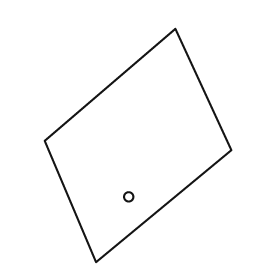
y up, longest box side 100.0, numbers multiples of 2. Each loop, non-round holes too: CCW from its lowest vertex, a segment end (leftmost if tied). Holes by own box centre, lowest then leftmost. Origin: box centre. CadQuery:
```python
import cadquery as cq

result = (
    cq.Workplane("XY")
    .moveTo(-18.0, -50.0)
    .lineTo(40.0, -2.0)
    .lineTo(16.0, 50.0)
    .lineTo(-40.0, 2.0)
    .close()
    .moveTo(-4.0, -22.0)
    .circle(2.0)
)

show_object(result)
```